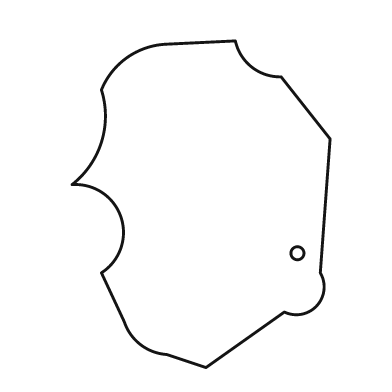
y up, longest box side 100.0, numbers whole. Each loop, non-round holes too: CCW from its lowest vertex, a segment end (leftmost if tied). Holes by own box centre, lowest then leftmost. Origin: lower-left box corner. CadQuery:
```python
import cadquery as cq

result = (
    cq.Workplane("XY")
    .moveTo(41.0, 0.0)
    .lineTo(65.0, 17.0)
    .threePointArc((75.0, 19.0), (76.0, 29.0))
    .lineTo(79.0, 70.0)
    .lineTo(64.0, 89.0)
    .threePointArc((55.0, 92.0), (50.0, 100.0))
    .lineTo(29.0, 99.0)
    .threePointArc((17.0, 95.0), (9.0, 85.0))
    .threePointArc((9.0, 69.0), (0.0, 56.0))
    .threePointArc((15.0, 46.0), (9.0, 29.0))
    .lineTo(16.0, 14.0)
    .threePointArc((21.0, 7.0), (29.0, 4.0))
    .close()
    .moveTo(69.0, 35.0)
    .circle(2.0)
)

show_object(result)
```